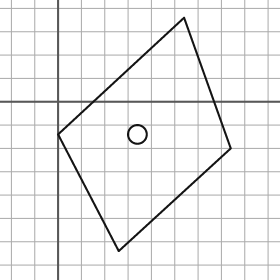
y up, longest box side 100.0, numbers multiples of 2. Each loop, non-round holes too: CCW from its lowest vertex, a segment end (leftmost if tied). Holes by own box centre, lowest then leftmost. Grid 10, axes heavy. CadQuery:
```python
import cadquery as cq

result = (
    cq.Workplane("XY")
    .moveTo(26.0, -64.0)
    .lineTo(74.0, -20.0)
    .lineTo(54.0, 36.0)
    .lineTo(0.0, -14.0)
    .close()
    .moveTo(34.0, -14.0)
    .circle(4.0)
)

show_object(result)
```